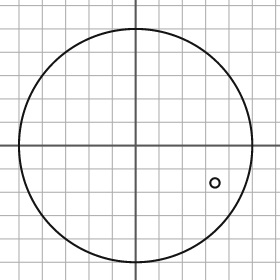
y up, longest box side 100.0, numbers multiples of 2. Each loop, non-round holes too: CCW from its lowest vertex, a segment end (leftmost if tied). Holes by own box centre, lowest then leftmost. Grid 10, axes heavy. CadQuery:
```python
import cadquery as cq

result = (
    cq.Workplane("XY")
    .moveTo(0.0, 0.0)
    .circle(50.0)
    .moveTo(34.0, -16.0)
    .circle(2.0)
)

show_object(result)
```